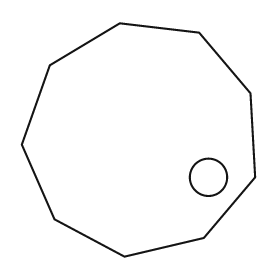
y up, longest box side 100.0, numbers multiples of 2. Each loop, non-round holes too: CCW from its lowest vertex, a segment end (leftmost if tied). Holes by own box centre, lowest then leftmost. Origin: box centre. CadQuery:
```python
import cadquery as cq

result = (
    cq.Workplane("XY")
    .moveTo(-6.0, -50.0)
    .lineTo(28.0, -42.0)
    .lineTo(50.0, -16.0)
    .lineTo(48.0, 20.0)
    .lineTo(26.0, 46.0)
    .lineTo(-8.0, 50.0)
    .lineTo(-38.0, 32.0)
    .lineTo(-50.0, -2.0)
    .lineTo(-36.0, -34.0)
    .close()
    .moveTo(30.0, -16.0)
    .circle(8.0)
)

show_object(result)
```